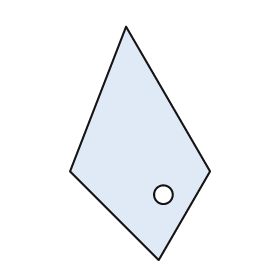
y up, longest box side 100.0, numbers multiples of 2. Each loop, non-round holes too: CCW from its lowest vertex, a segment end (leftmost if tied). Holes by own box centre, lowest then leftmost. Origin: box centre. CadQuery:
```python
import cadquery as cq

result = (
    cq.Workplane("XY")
    .moveTo(8.0, -50.0)
    .lineTo(30.0, -12.0)
    .lineTo(-6.0, 50.0)
    .lineTo(-30.0, -12.0)
    .close()
    .moveTo(10.0, -22.0)
    .circle(4.0)
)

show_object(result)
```